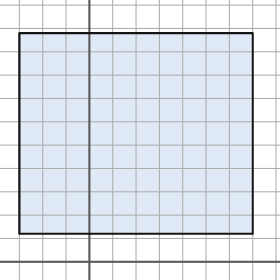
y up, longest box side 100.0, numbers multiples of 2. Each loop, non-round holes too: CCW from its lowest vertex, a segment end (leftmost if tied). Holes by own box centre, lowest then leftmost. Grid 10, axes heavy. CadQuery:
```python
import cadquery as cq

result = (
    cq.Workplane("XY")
    .moveTo(-30.0, 12.0)
    .lineTo(70.0, 12.0)
    .lineTo(70.0, 98.0)
    .lineTo(-30.0, 98.0)
    .close()
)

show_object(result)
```